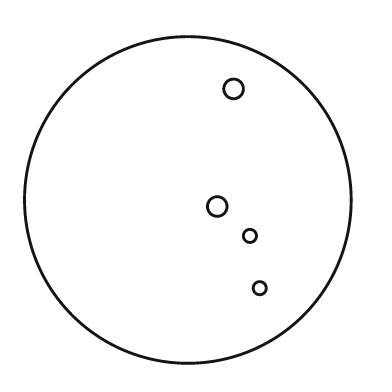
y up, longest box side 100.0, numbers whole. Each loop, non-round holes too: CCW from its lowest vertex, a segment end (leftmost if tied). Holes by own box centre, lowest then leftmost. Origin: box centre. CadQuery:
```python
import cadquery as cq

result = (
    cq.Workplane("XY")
    .moveTo(0.0, 0.0)
    .circle(50.0)
    .moveTo(22.0, -27.0)
    .circle(2.0)
    .moveTo(19.0, -11.0)
    .circle(2.0)
    .moveTo(9.0, -2.0)
    .circle(3.0)
    .moveTo(14.0, 34.0)
    .circle(3.0)
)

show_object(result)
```